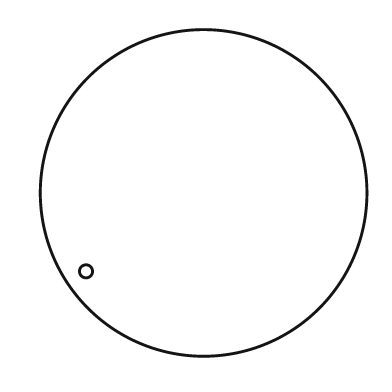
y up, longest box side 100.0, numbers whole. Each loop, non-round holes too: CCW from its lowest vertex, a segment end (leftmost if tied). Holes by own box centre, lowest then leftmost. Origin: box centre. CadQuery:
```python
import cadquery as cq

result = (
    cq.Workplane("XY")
    .moveTo(0.0, 0.0)
    .circle(50.0)
    .moveTo(-36.0, -24.0)
    .circle(2.0)
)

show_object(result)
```